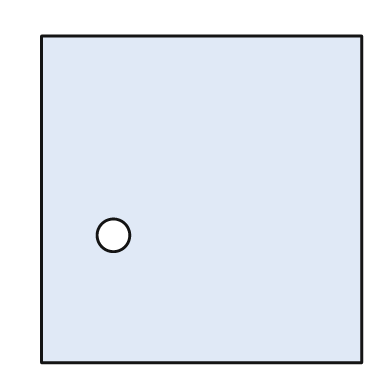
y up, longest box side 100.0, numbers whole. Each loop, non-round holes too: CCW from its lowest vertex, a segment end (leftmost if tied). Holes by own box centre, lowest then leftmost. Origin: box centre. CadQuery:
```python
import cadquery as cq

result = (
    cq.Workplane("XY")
    .moveTo(-49.0, -50.0)
    .lineTo(49.0, -50.0)
    .lineTo(49.0, 50.0)
    .lineTo(-49.0, 50.0)
    .close()
    .moveTo(-27.0, -11.0)
    .circle(5.0)
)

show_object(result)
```